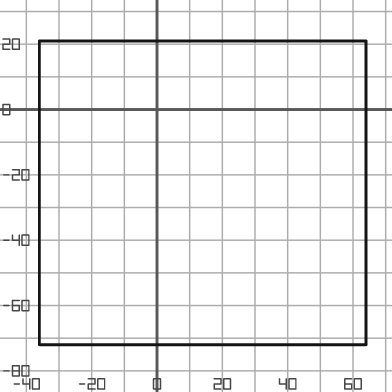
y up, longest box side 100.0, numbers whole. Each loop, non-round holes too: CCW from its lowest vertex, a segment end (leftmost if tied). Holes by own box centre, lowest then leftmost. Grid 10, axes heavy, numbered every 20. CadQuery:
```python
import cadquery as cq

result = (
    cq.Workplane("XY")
    .moveTo(-36.0, -72.0)
    .lineTo(64.0, -72.0)
    .lineTo(64.0, 21.0)
    .lineTo(-36.0, 21.0)
    .close()
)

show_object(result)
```